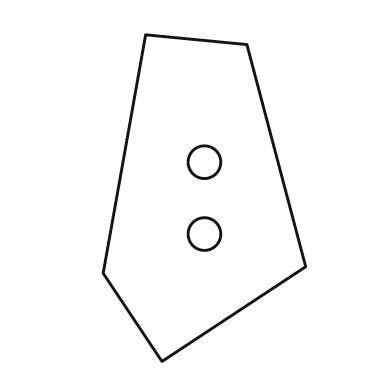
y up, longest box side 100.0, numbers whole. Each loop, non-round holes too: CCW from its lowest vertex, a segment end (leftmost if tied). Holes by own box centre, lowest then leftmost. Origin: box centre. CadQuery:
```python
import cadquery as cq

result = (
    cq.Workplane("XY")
    .moveTo(-13.0, -50.0)
    .lineTo(31.0, -21.0)
    .lineTo(13.0, 47.0)
    .lineTo(-18.0, 50.0)
    .lineTo(-31.0, -23.0)
    .close()
    .moveTo(0.0, -11.0)
    .circle(5.0)
    .moveTo(0.0, 11.0)
    .circle(5.0)
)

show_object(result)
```